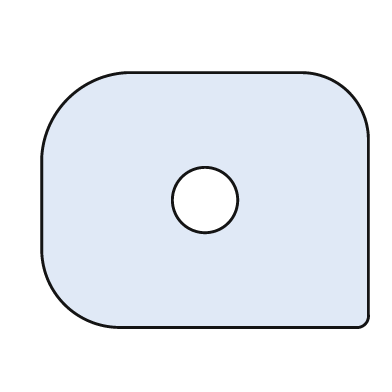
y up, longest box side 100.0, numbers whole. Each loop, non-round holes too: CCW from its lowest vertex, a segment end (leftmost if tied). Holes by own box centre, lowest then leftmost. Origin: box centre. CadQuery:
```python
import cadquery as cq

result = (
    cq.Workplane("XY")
    .moveTo(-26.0, -39.0)
    .lineTo(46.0, -39.0)
    .threePointArc((49.0, -38.0), (50.0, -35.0))
    .lineTo(50.0, 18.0)
    .threePointArc((44.0, 33.0), (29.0, 39.0))
    .lineTo(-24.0, 39.0)
    .threePointArc((-42.0, 31.0), (-50.0, 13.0))
    .lineTo(-50.0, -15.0)
    .threePointArc((-43.0, -32.0), (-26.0, -39.0))
    .close()
    .moveTo(0.0, 0.0)
    .circle(10.0)
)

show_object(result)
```